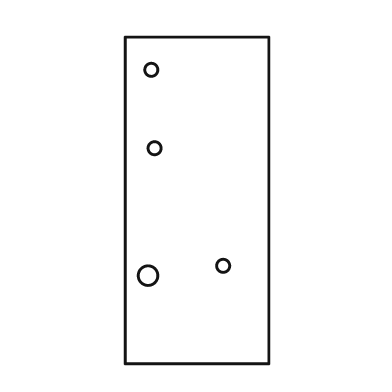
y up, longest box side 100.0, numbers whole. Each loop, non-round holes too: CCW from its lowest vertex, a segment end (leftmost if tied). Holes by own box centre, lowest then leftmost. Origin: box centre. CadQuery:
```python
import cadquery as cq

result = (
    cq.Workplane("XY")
    .moveTo(-22.0, -50.0)
    .lineTo(22.0, -50.0)
    .lineTo(22.0, 50.0)
    .lineTo(-22.0, 50.0)
    .close()
    .moveTo(-15.0, -23.0)
    .circle(3.0)
    .moveTo(8.0, -20.0)
    .circle(2.0)
    .moveTo(-13.0, 16.0)
    .circle(2.0)
    .moveTo(-14.0, 40.0)
    .circle(2.0)
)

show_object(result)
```